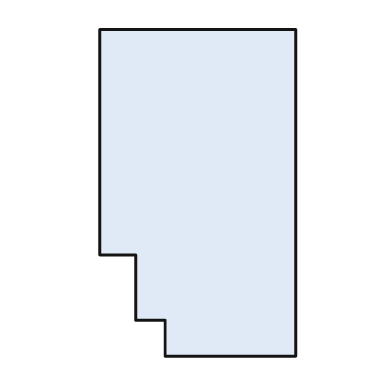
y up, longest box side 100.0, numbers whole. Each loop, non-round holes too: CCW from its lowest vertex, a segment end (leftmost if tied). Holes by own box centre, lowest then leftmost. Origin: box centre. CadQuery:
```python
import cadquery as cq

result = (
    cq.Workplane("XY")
    .moveTo(-10.0, -50.0)
    .lineTo(30.0, -50.0)
    .lineTo(30.0, 50.0)
    .lineTo(-30.0, 50.0)
    .lineTo(-30.0, -19.0)
    .lineTo(-19.0, -19.0)
    .lineTo(-19.0, -39.0)
    .lineTo(-10.0, -39.0)
    .close()
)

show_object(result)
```